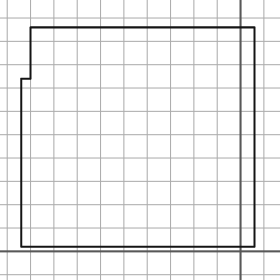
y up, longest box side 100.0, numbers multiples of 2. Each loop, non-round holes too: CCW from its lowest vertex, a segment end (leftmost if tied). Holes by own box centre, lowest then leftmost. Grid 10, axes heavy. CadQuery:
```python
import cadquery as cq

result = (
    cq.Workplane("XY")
    .moveTo(-94.0, 2.0)
    .lineTo(6.0, 2.0)
    .lineTo(6.0, 96.0)
    .lineTo(-90.0, 96.0)
    .lineTo(-90.0, 74.0)
    .lineTo(-94.0, 74.0)
    .close()
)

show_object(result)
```